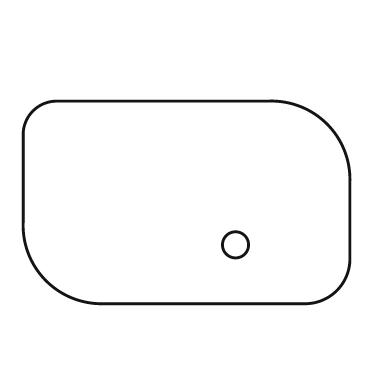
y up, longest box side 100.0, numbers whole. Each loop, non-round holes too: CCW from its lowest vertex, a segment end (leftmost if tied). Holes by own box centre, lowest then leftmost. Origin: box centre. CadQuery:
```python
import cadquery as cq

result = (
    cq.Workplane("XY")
    .moveTo(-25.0, -31.0)
    .lineTo(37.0, -31.0)
    .threePointArc((46.0, -27.0), (50.0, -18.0))
    .lineTo(50.0, 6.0)
    .threePointArc((43.0, 24.0), (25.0, 31.0))
    .lineTo(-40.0, 31.0)
    .threePointArc((-47.0, 28.0), (-50.0, 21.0))
    .lineTo(-50.0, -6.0)
    .threePointArc((-43.0, -24.0), (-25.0, -31.0))
    .close()
    .moveTo(15.0, -13.0)
    .circle(4.0)
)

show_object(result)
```